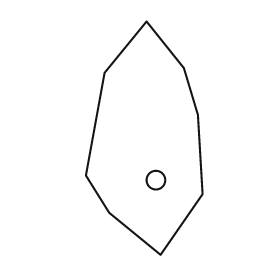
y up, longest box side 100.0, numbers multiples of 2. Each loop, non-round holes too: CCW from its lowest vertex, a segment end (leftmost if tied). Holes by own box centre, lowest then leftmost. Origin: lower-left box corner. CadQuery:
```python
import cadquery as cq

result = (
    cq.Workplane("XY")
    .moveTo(32.0, 0.0)
    .lineTo(50.0, 26.0)
    .lineTo(48.0, 60.0)
    .lineTo(42.0, 80.0)
    .lineTo(26.0, 100.0)
    .lineTo(8.0, 78.0)
    .lineTo(0.0, 34.0)
    .lineTo(10.0, 18.0)
    .close()
    .moveTo(30.0, 32.0)
    .circle(4.0)
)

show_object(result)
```